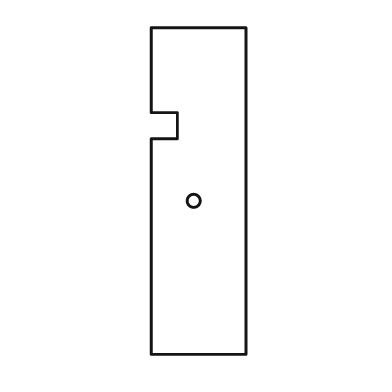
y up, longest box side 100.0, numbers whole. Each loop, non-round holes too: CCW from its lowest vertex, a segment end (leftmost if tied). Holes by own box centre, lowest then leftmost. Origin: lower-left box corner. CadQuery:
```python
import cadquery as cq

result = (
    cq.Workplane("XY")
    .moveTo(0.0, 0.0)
    .lineTo(29.0, 0.0)
    .lineTo(29.0, 100.0)
    .lineTo(0.0, 100.0)
    .lineTo(0.0, 74.0)
    .lineTo(8.0, 74.0)
    .lineTo(8.0, 66.0)
    .lineTo(0.0, 66.0)
    .close()
    .moveTo(13.0, 47.0)
    .circle(2.0)
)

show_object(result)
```